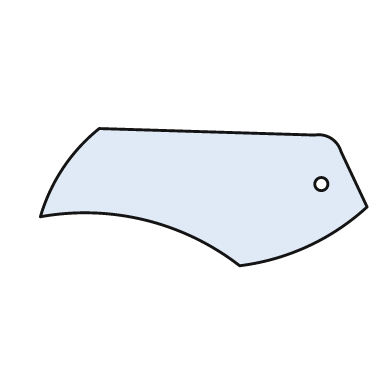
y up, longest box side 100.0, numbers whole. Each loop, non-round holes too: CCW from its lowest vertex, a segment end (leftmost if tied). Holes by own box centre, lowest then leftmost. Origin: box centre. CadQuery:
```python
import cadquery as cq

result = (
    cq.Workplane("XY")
    .moveTo(11.0, -21.0)
    .threePointArc((32.0, -15.0), (50.0, -3.0))
    .lineTo(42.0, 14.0)
    .threePointArc((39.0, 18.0), (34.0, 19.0))
    .lineTo(-32.0, 21.0)
    .threePointArc((-43.0, 9.0), (-50.0, -6.0))
    .threePointArc((-18.0, -7.0), (11.0, -21.0))
    .close()
    .moveTo(36.0, 4.0)
    .circle(2.0)
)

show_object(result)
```